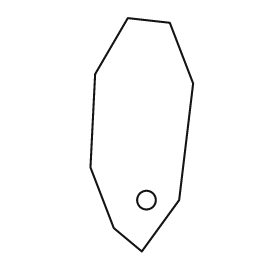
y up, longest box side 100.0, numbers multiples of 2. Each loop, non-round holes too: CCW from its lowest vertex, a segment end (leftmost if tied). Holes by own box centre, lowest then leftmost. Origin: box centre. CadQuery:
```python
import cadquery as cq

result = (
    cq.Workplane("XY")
    .moveTo(0.0, -50.0)
    .lineTo(16.0, -28.0)
    .lineTo(22.0, 22.0)
    .lineTo(12.0, 48.0)
    .lineTo(-6.0, 50.0)
    .lineTo(-20.0, 26.0)
    .lineTo(-22.0, -14.0)
    .lineTo(-12.0, -40.0)
    .close()
    .moveTo(2.0, -28.0)
    .circle(4.0)
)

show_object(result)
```